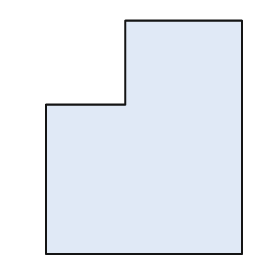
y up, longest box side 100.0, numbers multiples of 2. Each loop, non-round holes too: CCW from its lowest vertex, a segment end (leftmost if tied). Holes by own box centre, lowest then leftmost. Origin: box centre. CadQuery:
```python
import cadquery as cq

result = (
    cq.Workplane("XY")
    .moveTo(-42.0, -50.0)
    .lineTo(42.0, -50.0)
    .lineTo(42.0, 50.0)
    .lineTo(-8.0, 50.0)
    .lineTo(-8.0, 14.0)
    .lineTo(-42.0, 14.0)
    .close()
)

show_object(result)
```